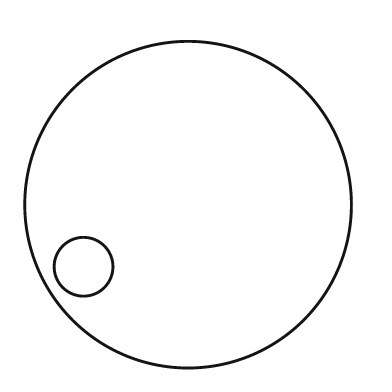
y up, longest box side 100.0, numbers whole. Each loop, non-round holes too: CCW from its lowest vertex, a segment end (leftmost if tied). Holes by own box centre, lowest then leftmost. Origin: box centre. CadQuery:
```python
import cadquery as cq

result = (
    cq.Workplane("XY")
    .moveTo(0.0, 0.0)
    .circle(50.0)
    .moveTo(-32.0, -19.0)
    .circle(9.0)
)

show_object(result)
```